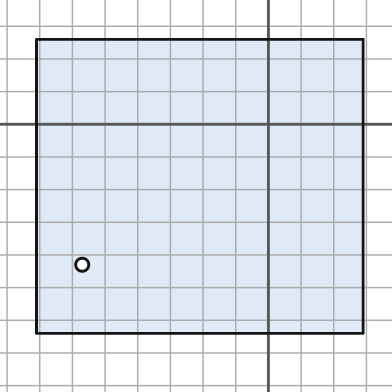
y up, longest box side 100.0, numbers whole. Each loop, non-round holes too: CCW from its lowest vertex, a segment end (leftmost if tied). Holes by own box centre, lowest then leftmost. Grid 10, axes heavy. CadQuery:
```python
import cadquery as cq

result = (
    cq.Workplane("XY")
    .moveTo(-71.0, -64.0)
    .lineTo(29.0, -64.0)
    .lineTo(29.0, 26.0)
    .lineTo(-71.0, 26.0)
    .close()
    .moveTo(-57.0, -43.0)
    .circle(2.0)
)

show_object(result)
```